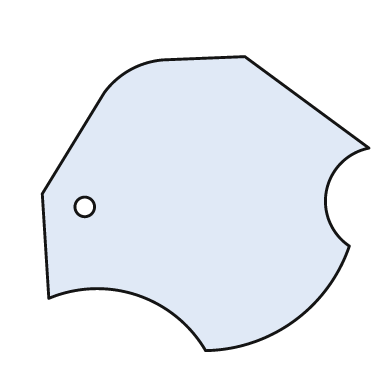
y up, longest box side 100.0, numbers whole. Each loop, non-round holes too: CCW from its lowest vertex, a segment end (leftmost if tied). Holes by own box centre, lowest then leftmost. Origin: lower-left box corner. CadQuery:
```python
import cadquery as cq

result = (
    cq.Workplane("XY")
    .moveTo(50.0, 0.0)
    .threePointArc((77.0, 9.0), (94.0, 32.0))
    .threePointArc((87.0, 49.0), (100.0, 62.0))
    .lineTo(62.0, 90.0)
    .lineTo(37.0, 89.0)
    .threePointArc((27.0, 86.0), (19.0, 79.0))
    .lineTo(0.0, 48.0)
    .lineTo(2.0, 16.0)
    .threePointArc((29.0, 17.0), (50.0, 0.0))
    .close()
    .moveTo(13.0, 44.0)
    .circle(3.0)
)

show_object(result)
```